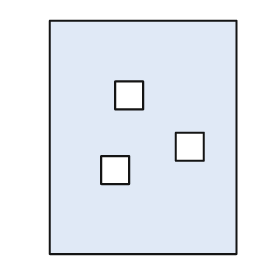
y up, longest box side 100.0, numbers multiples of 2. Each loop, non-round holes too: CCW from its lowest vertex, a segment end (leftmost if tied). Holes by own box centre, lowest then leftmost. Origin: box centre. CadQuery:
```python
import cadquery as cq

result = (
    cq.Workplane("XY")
    .moveTo(-40.0, -50.0)
    .lineTo(40.0, -50.0)
    .lineTo(40.0, 50.0)
    .lineTo(-40.0, 50.0)
    .close()
    .moveTo(-18.0, -20.0)
    .lineTo(-6.0, -20.0)
    .lineTo(-6.0, -8.0)
    .lineTo(-18.0, -8.0)
    .close()
    .moveTo(14.0, -10.0)
    .lineTo(26.0, -10.0)
    .lineTo(26.0, 2.0)
    .lineTo(14.0, 2.0)
    .close()
    .moveTo(-12.0, 12.0)
    .lineTo(0.0, 12.0)
    .lineTo(0.0, 24.0)
    .lineTo(-12.0, 24.0)
    .close()
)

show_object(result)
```